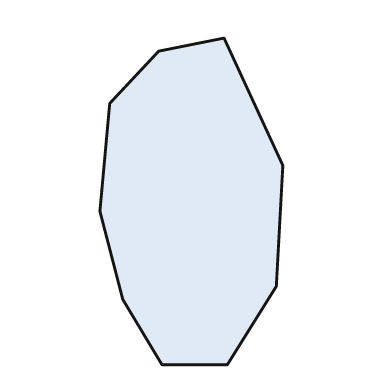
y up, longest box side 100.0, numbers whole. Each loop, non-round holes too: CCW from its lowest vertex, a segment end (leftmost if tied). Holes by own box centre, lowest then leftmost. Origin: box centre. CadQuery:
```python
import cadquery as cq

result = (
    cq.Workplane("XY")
    .moveTo(-9.0, -50.0)
    .lineTo(11.0, -50.0)
    .lineTo(26.0, -26.0)
    .lineTo(28.0, 11.0)
    .lineTo(10.0, 50.0)
    .lineTo(-10.0, 46.0)
    .lineTo(-25.0, 30.0)
    .lineTo(-28.0, -3.0)
    .lineTo(-21.0, -30.0)
    .close()
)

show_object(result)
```